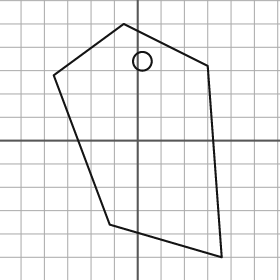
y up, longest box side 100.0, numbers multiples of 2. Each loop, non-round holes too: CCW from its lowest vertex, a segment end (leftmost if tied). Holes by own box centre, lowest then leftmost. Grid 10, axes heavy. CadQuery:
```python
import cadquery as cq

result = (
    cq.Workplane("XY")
    .moveTo(36.0, -50.0)
    .lineTo(30.0, 32.0)
    .lineTo(-6.0, 50.0)
    .lineTo(-36.0, 28.0)
    .lineTo(-12.0, -36.0)
    .close()
    .moveTo(2.0, 34.0)
    .circle(4.0)
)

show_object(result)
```